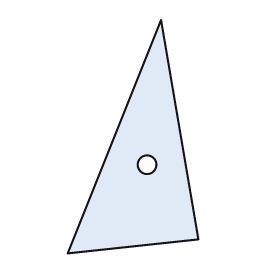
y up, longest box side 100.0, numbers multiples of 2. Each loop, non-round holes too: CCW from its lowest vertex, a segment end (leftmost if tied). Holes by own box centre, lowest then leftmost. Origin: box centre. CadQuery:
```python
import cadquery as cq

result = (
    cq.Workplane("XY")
    .moveTo(-28.0, -50.0)
    .lineTo(28.0, -44.0)
    .lineTo(12.0, 50.0)
    .close()
    .moveTo(6.0, -12.0)
    .circle(4.0)
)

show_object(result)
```